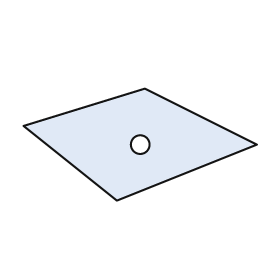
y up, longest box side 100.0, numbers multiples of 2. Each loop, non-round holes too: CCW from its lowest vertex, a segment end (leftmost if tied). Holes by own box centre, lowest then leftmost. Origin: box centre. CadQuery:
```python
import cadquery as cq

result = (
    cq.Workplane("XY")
    .moveTo(-10.0, -24.0)
    .lineTo(50.0, 0.0)
    .lineTo(2.0, 24.0)
    .lineTo(-50.0, 8.0)
    .close()
    .moveTo(0.0, 0.0)
    .circle(4.0)
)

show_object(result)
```